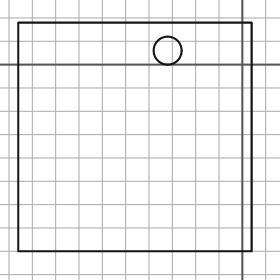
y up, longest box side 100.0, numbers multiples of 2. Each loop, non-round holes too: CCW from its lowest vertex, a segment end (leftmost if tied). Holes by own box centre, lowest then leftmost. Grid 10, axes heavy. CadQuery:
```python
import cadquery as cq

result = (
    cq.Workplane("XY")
    .moveTo(-96.0, -80.0)
    .lineTo(4.0, -80.0)
    .lineTo(4.0, 18.0)
    .lineTo(-96.0, 18.0)
    .close()
    .moveTo(-32.0, 6.0)
    .circle(6.0)
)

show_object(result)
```